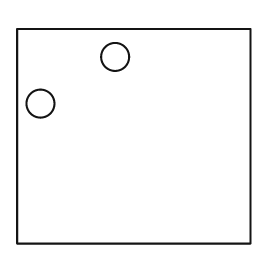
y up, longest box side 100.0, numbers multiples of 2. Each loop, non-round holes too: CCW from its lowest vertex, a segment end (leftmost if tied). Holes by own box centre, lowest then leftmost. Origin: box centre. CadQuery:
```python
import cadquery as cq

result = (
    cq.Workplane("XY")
    .moveTo(-50.0, -46.0)
    .lineTo(50.0, -46.0)
    .lineTo(50.0, 46.0)
    .lineTo(-50.0, 46.0)
    .close()
    .moveTo(-40.0, 14.0)
    .circle(6.0)
    .moveTo(-8.0, 34.0)
    .circle(6.0)
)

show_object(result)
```